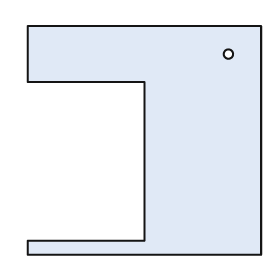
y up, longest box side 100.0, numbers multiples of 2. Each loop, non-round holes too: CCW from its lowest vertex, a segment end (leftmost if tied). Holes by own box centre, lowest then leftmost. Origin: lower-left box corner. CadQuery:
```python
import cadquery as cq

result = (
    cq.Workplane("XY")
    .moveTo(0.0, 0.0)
    .lineTo(100.0, 0.0)
    .lineTo(100.0, 98.0)
    .lineTo(0.0, 98.0)
    .lineTo(0.0, 74.0)
    .lineTo(50.0, 74.0)
    .lineTo(50.0, 6.0)
    .lineTo(0.0, 6.0)
    .close()
    .moveTo(86.0, 86.0)
    .circle(2.0)
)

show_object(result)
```